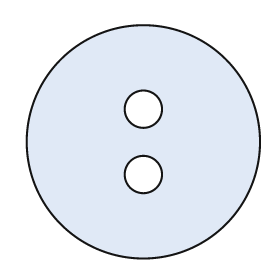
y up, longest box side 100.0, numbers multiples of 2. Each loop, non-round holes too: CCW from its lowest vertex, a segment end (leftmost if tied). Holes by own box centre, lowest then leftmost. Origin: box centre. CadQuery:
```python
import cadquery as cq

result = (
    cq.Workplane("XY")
    .moveTo(0.0, 0.0)
    .circle(50.0)
    .moveTo(0.0, -14.0)
    .circle(8.0)
    .moveTo(0.0, 14.0)
    .circle(8.0)
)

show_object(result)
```